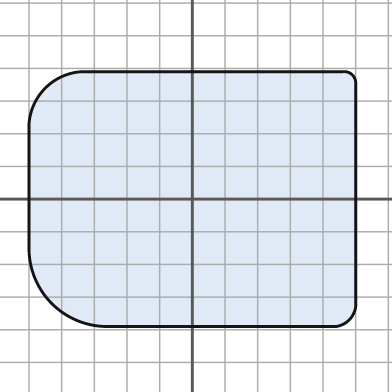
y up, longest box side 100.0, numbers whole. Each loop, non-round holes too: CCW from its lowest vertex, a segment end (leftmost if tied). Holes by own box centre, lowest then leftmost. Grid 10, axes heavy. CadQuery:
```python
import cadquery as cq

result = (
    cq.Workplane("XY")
    .moveTo(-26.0, -39.0)
    .lineTo(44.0, -39.0)
    .threePointArc((48.0, -37.0), (50.0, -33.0))
    .lineTo(50.0, 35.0)
    .threePointArc((49.0, 38.0), (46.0, 39.0))
    .lineTo(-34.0, 39.0)
    .threePointArc((-45.0, 34.0), (-50.0, 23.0))
    .lineTo(-50.0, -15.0)
    .threePointArc((-43.0, -32.0), (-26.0, -39.0))
    .close()
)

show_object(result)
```